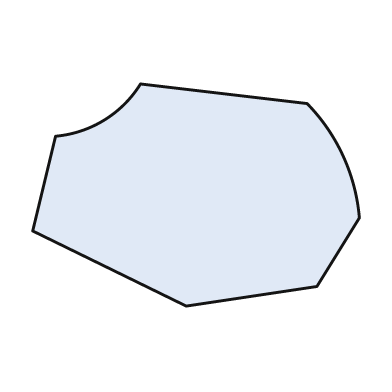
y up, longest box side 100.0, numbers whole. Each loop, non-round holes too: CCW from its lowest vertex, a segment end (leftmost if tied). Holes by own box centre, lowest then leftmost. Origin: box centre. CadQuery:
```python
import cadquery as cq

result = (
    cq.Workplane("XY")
    .moveTo(-3.0, -34.0)
    .lineTo(37.0, -28.0)
    .lineTo(50.0, -7.0)
    .threePointArc((45.0, 12.0), (34.0, 28.0))
    .lineTo(-17.0, 34.0)
    .threePointArc((-28.0, 23.0), (-43.0, 18.0))
    .lineTo(-50.0, -11.0)
    .close()
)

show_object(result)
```